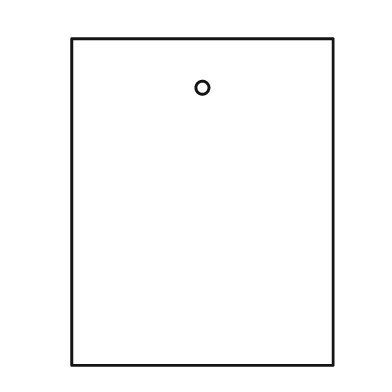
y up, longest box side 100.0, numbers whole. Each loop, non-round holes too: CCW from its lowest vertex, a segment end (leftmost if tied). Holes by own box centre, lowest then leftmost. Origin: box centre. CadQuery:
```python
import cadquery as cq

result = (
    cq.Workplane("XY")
    .moveTo(-40.0, -50.0)
    .lineTo(40.0, -50.0)
    .lineTo(40.0, 50.0)
    .lineTo(-40.0, 50.0)
    .close()
    .moveTo(0.0, 35.0)
    .circle(2.0)
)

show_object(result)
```